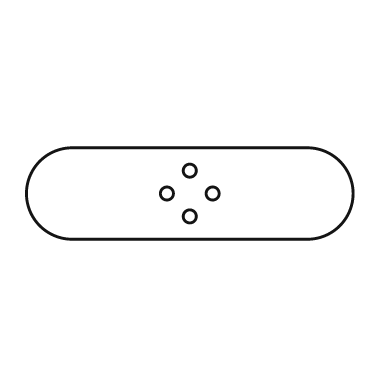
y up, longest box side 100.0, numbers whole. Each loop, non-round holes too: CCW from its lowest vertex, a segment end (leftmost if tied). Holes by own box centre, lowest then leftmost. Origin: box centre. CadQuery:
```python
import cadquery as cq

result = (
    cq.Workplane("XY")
    .moveTo(-36.0, -14.0)
    .lineTo(36.0, -14.0)
    .threePointArc((50.0, 0.0), (36.0, 14.0))
    .lineTo(-36.0, 14.0)
    .threePointArc((-50.0, 0.0), (-36.0, -14.0))
    .close()
    .moveTo(0.0, -7.0)
    .circle(2.0)
    .moveTo(-7.0, 0.0)
    .circle(2.0)
    .moveTo(7.0, 0.0)
    .circle(2.0)
    .moveTo(0.0, 7.0)
    .circle(2.0)
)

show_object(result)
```